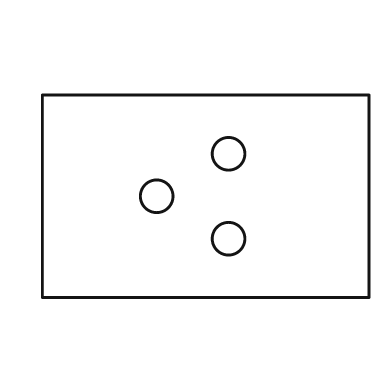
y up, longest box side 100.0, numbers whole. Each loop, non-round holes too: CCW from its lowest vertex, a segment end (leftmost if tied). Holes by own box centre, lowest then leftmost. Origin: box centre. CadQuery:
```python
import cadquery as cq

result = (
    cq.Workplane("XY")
    .moveTo(-50.0, -31.0)
    .lineTo(50.0, -31.0)
    .lineTo(50.0, 31.0)
    .lineTo(-50.0, 31.0)
    .close()
    .moveTo(7.0, -13.0)
    .circle(5.0)
    .moveTo(-15.0, 0.0)
    .circle(5.0)
    .moveTo(7.0, 13.0)
    .circle(5.0)
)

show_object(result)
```